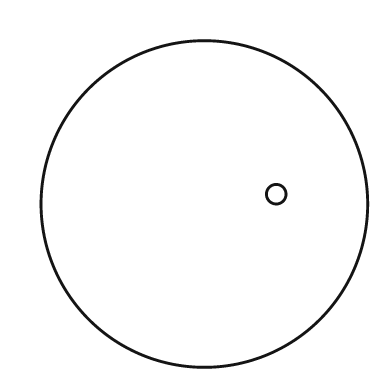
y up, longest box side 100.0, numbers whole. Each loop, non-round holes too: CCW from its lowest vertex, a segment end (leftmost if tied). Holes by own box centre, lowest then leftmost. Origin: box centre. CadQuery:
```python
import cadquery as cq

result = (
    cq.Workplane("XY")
    .moveTo(0.0, 0.0)
    .circle(50.0)
    .moveTo(22.0, 3.0)
    .circle(3.0)
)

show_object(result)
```